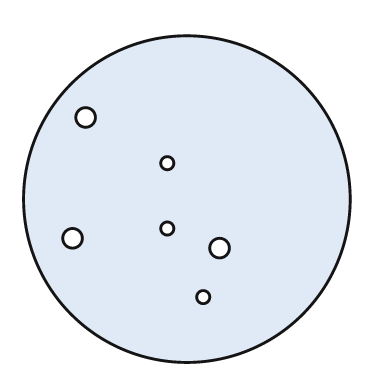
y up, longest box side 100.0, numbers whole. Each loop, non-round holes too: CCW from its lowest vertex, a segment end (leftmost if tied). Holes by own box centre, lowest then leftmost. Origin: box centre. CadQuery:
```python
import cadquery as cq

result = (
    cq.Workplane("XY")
    .moveTo(0.0, 0.0)
    .circle(50.0)
    .moveTo(5.0, -30.0)
    .circle(2.0)
    .moveTo(10.0, -15.0)
    .circle(3.0)
    .moveTo(-35.0, -12.0)
    .circle(3.0)
    .moveTo(-6.0, -9.0)
    .circle(2.0)
    .moveTo(-6.0, 11.0)
    .circle(2.0)
    .moveTo(-31.0, 25.0)
    .circle(3.0)
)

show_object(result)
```